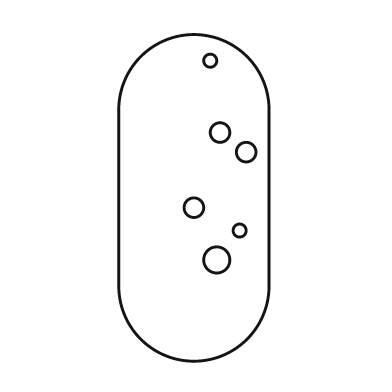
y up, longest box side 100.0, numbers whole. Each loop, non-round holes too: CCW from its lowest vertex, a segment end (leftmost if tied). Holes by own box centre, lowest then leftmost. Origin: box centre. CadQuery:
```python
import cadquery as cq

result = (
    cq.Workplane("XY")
    .moveTo(-23.0, -27.0)
    .threePointArc((0.0, -50.0), (23.0, -27.0))
    .lineTo(23.0, 27.0)
    .threePointArc((0.0, 50.0), (-23.0, 27.0))
    .close()
    .moveTo(7.0, -19.0)
    .circle(4.0)
    .moveTo(14.0, -10.0)
    .circle(2.0)
    .moveTo(0.0, -3.0)
    .circle(3.0)
    .moveTo(16.0, 14.0)
    .circle(3.0)
    .moveTo(8.0, 20.0)
    .circle(3.0)
    .moveTo(5.0, 42.0)
    .circle(2.0)
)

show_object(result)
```